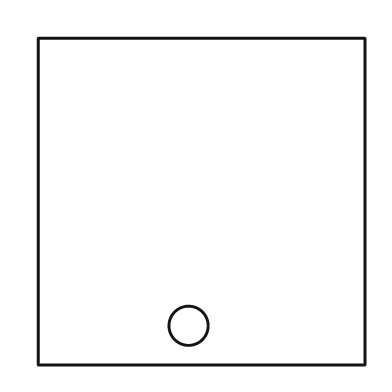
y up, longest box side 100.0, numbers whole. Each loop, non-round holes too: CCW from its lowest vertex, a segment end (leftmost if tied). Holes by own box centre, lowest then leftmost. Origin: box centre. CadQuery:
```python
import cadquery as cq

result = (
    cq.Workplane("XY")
    .moveTo(-50.0, -50.0)
    .lineTo(50.0, -50.0)
    .lineTo(50.0, 50.0)
    .lineTo(-50.0, 50.0)
    .close()
    .moveTo(-4.0, -38.0)
    .circle(6.0)
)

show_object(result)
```